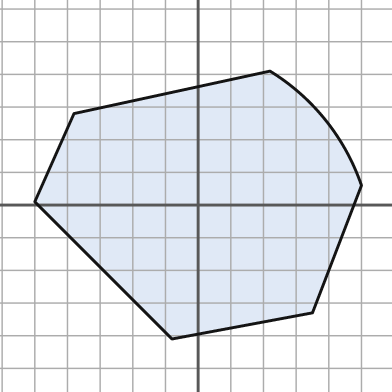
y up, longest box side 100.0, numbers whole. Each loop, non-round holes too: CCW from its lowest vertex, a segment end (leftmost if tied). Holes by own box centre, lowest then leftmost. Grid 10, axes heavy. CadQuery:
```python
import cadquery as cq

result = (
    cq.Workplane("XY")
    .moveTo(-8.0, -41.0)
    .lineTo(35.0, -33.0)
    .lineTo(50.0, 6.0)
    .threePointArc((39.0, 26.0), (22.0, 41.0))
    .lineTo(-38.0, 28.0)
    .lineTo(-50.0, 1.0)
    .close()
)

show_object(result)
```